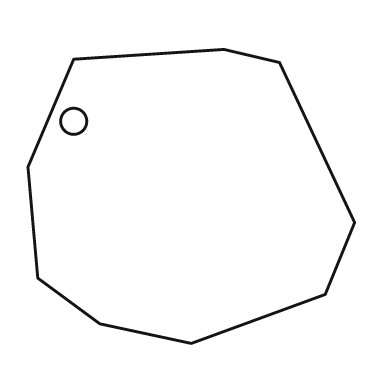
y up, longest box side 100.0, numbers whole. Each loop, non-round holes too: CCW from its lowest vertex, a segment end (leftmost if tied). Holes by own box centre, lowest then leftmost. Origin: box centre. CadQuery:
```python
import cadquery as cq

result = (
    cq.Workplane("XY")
    .moveTo(0.0, -45.0)
    .lineTo(41.0, -30.0)
    .lineTo(50.0, -8.0)
    .lineTo(27.0, 41.0)
    .lineTo(10.0, 45.0)
    .lineTo(-36.0, 42.0)
    .lineTo(-50.0, 9.0)
    .lineTo(-47.0, -25.0)
    .lineTo(-28.0, -39.0)
    .close()
    .moveTo(-36.0, 23.0)
    .circle(4.0)
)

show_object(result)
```